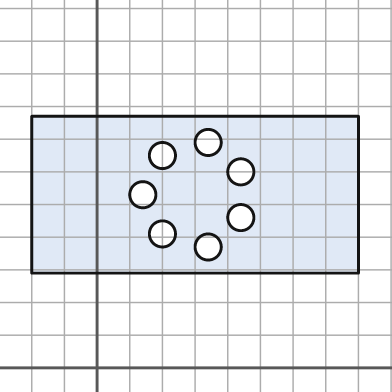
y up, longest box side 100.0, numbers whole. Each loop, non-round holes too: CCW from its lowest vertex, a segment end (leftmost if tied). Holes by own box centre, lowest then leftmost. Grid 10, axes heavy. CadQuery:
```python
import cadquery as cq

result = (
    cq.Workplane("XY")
    .moveTo(-20.0, 29.0)
    .lineTo(80.0, 29.0)
    .lineTo(80.0, 77.0)
    .lineTo(-20.0, 77.0)
    .close()
    .moveTo(34.0, 37.0)
    .circle(4.0)
    .moveTo(20.0, 41.0)
    .circle(4.0)
    .moveTo(44.0, 46.0)
    .circle(4.0)
    .moveTo(14.0, 53.0)
    .circle(4.0)
    .moveTo(44.0, 60.0)
    .circle(4.0)
    .moveTo(20.0, 65.0)
    .circle(4.0)
    .moveTo(34.0, 69.0)
    .circle(4.0)
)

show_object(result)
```